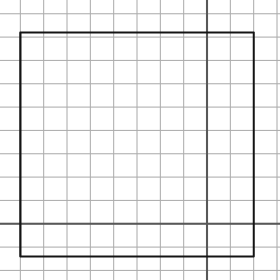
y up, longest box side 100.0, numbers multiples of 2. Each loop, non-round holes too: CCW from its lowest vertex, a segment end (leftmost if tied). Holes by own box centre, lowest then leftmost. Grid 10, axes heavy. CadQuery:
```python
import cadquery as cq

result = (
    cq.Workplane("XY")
    .moveTo(-80.0, -14.0)
    .lineTo(20.0, -14.0)
    .lineTo(20.0, 82.0)
    .lineTo(-80.0, 82.0)
    .close()
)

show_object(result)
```